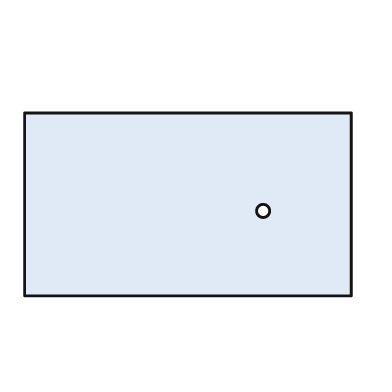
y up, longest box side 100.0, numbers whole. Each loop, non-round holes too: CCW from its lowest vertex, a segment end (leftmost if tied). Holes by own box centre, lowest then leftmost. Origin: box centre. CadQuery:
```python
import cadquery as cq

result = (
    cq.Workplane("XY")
    .moveTo(-50.0, -28.0)
    .lineTo(50.0, -28.0)
    .lineTo(50.0, 28.0)
    .lineTo(-50.0, 28.0)
    .close()
    .moveTo(23.0, -2.0)
    .circle(2.0)
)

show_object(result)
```